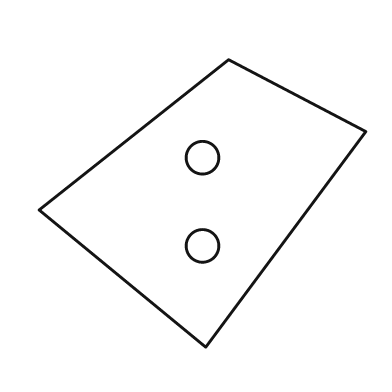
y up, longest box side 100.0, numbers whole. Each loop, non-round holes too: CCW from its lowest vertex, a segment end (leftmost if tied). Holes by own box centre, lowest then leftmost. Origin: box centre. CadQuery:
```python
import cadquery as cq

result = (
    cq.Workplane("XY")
    .moveTo(1.0, -44.0)
    .lineTo(50.0, 22.0)
    .lineTo(8.0, 44.0)
    .lineTo(-50.0, -2.0)
    .close()
    .moveTo(0.0, -13.0)
    .circle(5.0)
    .moveTo(0.0, 14.0)
    .circle(5.0)
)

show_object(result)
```